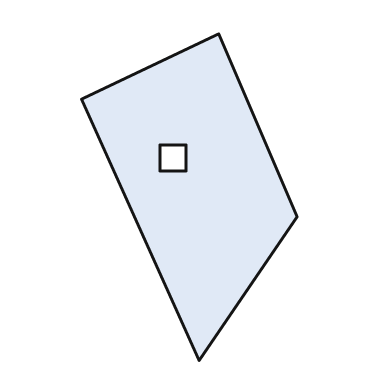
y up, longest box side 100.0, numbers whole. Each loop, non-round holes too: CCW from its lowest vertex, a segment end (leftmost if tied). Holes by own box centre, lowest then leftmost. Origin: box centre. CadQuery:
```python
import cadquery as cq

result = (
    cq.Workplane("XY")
    .moveTo(3.0, -50.0)
    .lineTo(33.0, -6.0)
    .lineTo(9.0, 50.0)
    .lineTo(-33.0, 30.0)
    .close()
    .moveTo(-9.0, 8.0)
    .lineTo(-1.0, 8.0)
    .lineTo(-1.0, 16.0)
    .lineTo(-9.0, 16.0)
    .close()
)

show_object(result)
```